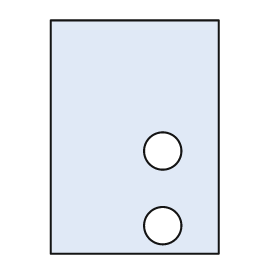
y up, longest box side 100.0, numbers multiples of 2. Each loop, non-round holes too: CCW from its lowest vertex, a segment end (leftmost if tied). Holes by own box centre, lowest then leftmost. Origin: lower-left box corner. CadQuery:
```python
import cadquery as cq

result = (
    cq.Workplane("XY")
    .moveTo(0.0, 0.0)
    .lineTo(72.0, 0.0)
    .lineTo(72.0, 100.0)
    .lineTo(0.0, 100.0)
    .close()
    .moveTo(48.0, 12.0)
    .circle(8.0)
    .moveTo(48.0, 44.0)
    .circle(8.0)
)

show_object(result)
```